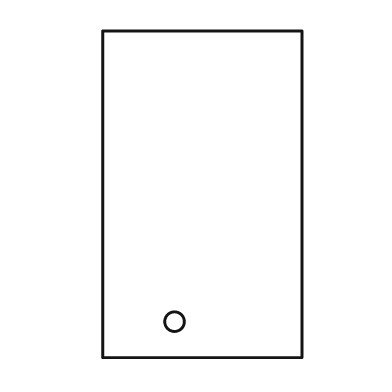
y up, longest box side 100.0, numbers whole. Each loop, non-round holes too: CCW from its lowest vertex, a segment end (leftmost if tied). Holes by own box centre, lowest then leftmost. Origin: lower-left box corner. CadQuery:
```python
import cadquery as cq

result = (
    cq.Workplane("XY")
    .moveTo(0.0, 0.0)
    .lineTo(61.0, 0.0)
    .lineTo(61.0, 100.0)
    .lineTo(0.0, 100.0)
    .close()
    .moveTo(22.0, 11.0)
    .circle(3.0)
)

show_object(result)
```